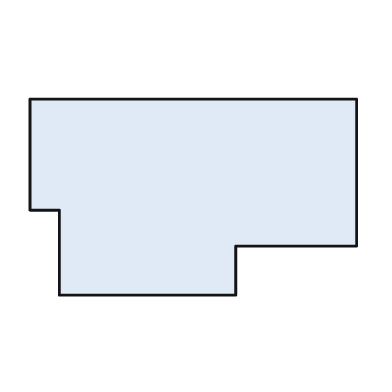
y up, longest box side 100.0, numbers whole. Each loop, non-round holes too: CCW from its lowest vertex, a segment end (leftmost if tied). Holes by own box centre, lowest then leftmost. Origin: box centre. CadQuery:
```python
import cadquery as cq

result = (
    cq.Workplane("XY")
    .moveTo(-41.0, -30.0)
    .lineTo(13.0, -30.0)
    .lineTo(13.0, -15.0)
    .lineTo(50.0, -15.0)
    .lineTo(50.0, 30.0)
    .lineTo(-50.0, 30.0)
    .lineTo(-50.0, -4.0)
    .lineTo(-41.0, -4.0)
    .close()
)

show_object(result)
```